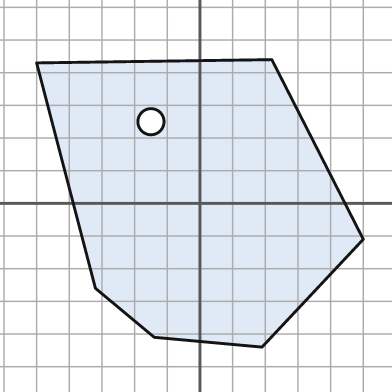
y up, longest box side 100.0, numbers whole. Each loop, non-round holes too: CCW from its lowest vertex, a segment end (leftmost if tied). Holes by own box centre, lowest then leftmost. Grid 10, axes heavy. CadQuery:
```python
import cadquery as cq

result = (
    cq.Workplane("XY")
    .moveTo(19.0, -44.0)
    .lineTo(50.0, -11.0)
    .lineTo(22.0, 44.0)
    .lineTo(-50.0, 43.0)
    .lineTo(-32.0, -26.0)
    .lineTo(-14.0, -41.0)
    .close()
    .moveTo(-15.0, 25.0)
    .circle(4.0)
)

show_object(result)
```